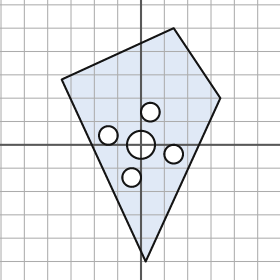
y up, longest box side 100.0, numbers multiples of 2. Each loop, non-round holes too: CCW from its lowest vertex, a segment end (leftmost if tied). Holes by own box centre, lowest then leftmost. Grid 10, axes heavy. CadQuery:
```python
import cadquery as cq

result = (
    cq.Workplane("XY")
    .moveTo(2.0, -50.0)
    .lineTo(34.0, 20.0)
    .lineTo(14.0, 50.0)
    .lineTo(-34.0, 28.0)
    .close()
    .moveTo(-4.0, -14.0)
    .circle(4.0)
    .moveTo(14.0, -4.0)
    .circle(4.0)
    .moveTo(0.0, 0.0)
    .circle(6.0)
    .moveTo(-14.0, 4.0)
    .circle(4.0)
    .moveTo(4.0, 14.0)
    .circle(4.0)
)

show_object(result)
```